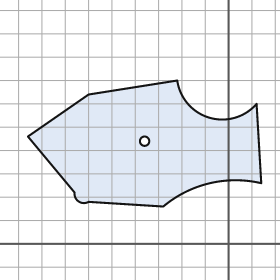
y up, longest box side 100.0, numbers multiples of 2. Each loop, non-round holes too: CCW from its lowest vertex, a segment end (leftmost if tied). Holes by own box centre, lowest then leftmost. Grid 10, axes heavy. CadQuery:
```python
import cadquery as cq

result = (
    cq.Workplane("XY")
    .moveTo(-28.0, 16.0)
    .threePointArc((-8.0, 26.0), (14.0, 26.0))
    .lineTo(12.0, 60.0)
    .threePointArc((-8.0, 54.0), (-22.0, 70.0))
    .lineTo(-60.0, 64.0)
    .lineTo(-86.0, 46.0)
    .lineTo(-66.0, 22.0)
    .threePointArc((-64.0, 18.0), (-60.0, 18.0))
    .close()
    .moveTo(-36.0, 44.0)
    .circle(2.0)
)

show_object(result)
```